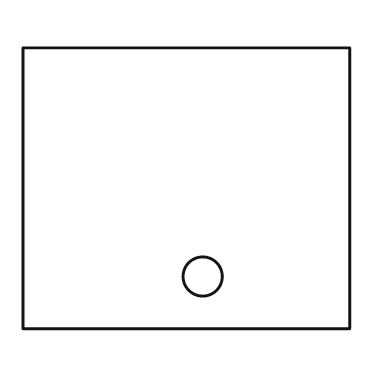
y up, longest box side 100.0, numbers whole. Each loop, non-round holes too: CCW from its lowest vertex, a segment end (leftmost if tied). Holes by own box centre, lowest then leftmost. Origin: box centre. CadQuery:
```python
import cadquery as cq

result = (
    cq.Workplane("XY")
    .moveTo(-50.0, -43.0)
    .lineTo(50.0, -43.0)
    .lineTo(50.0, 43.0)
    .lineTo(-50.0, 43.0)
    .close()
    .moveTo(5.0, -27.0)
    .circle(6.0)
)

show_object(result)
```